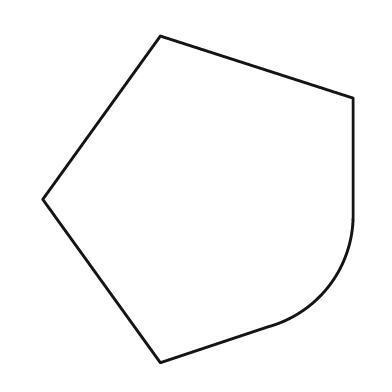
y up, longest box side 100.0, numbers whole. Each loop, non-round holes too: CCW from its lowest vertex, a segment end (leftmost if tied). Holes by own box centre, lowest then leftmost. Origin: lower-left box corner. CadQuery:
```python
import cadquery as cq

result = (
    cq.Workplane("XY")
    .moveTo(36.0, 0.0)
    .lineTo(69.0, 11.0)
    .threePointArc((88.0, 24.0), (95.0, 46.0))
    .lineTo(95.0, 81.0)
    .lineTo(36.0, 100.0)
    .lineTo(0.0, 50.0)
    .close()
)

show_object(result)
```